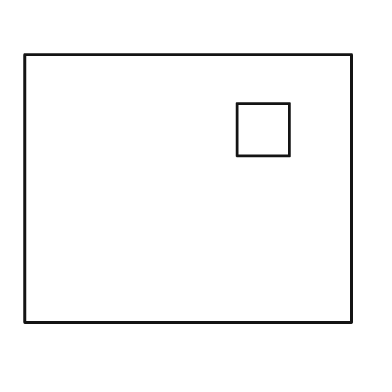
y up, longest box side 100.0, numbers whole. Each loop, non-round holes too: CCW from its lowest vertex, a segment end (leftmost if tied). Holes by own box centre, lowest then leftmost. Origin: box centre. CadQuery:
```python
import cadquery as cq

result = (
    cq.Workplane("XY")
    .moveTo(-50.0, -41.0)
    .lineTo(50.0, -41.0)
    .lineTo(50.0, 41.0)
    .lineTo(-50.0, 41.0)
    .close()
    .moveTo(15.0, 10.0)
    .lineTo(31.0, 10.0)
    .lineTo(31.0, 26.0)
    .lineTo(15.0, 26.0)
    .close()
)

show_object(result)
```